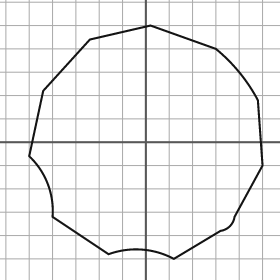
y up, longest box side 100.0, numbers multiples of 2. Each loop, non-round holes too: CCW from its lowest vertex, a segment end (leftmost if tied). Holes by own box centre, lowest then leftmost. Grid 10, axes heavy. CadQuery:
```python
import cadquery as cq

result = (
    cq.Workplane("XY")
    .moveTo(12.0, -50.0)
    .lineTo(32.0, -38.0)
    .threePointArc((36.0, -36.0), (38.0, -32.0))
    .lineTo(50.0, -10.0)
    .lineTo(48.0, 18.0)
    .threePointArc((40.0, 30.0), (30.0, 40.0))
    .lineTo(2.0, 50.0)
    .lineTo(-24.0, 44.0)
    .lineTo(-44.0, 22.0)
    .lineTo(-50.0, -6.0)
    .threePointArc((-42.0, -18.0), (-40.0, -32.0))
    .lineTo(-16.0, -48.0)
    .threePointArc((-2.0, -46.0), (12.0, -50.0))
    .close()
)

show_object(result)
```